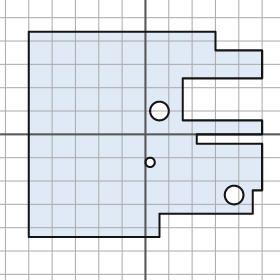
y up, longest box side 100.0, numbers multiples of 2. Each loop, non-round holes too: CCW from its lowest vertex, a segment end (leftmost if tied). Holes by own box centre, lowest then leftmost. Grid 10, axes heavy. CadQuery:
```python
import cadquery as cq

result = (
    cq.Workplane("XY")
    .moveTo(-50.0, -44.0)
    .lineTo(6.0, -44.0)
    .lineTo(6.0, -34.0)
    .lineTo(46.0, -34.0)
    .lineTo(46.0, -24.0)
    .lineTo(50.0, -24.0)
    .lineTo(50.0, -4.0)
    .lineTo(22.0, -4.0)
    .lineTo(22.0, 0.0)
    .lineTo(50.0, 0.0)
    .lineTo(50.0, 6.0)
    .lineTo(16.0, 6.0)
    .lineTo(16.0, 24.0)
    .lineTo(50.0, 24.0)
    .lineTo(50.0, 36.0)
    .lineTo(30.0, 36.0)
    .lineTo(30.0, 44.0)
    .lineTo(-50.0, 44.0)
    .close()
    .moveTo(38.0, -26.0)
    .circle(4.0)
    .moveTo(2.0, -12.0)
    .circle(2.0)
    .moveTo(6.0, 10.0)
    .circle(4.0)
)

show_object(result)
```